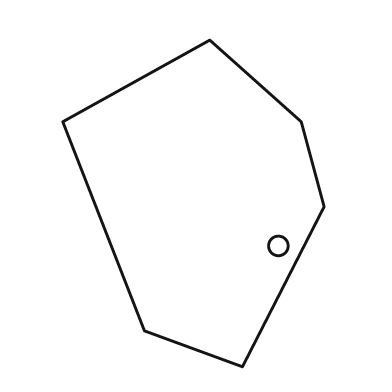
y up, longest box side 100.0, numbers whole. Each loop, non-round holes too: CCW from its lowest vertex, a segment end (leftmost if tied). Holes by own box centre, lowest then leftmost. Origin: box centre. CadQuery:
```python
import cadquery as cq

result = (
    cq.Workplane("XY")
    .moveTo(15.0, -50.0)
    .lineTo(40.0, -1.0)
    .lineTo(33.0, 25.0)
    .lineTo(5.0, 50.0)
    .lineTo(-40.0, 25.0)
    .lineTo(-15.0, -39.0)
    .close()
    .moveTo(26.0, -13.0)
    .circle(3.0)
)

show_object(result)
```